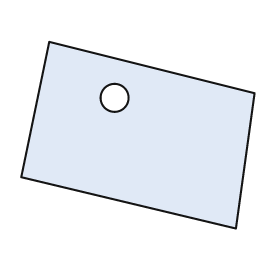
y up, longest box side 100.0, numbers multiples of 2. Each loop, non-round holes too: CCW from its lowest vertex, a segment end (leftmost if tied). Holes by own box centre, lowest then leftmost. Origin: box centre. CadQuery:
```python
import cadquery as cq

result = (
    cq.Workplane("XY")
    .moveTo(42.0, -40.0)
    .lineTo(50.0, 18.0)
    .lineTo(-38.0, 40.0)
    .lineTo(-50.0, -18.0)
    .close()
    .moveTo(-10.0, 16.0)
    .circle(6.0)
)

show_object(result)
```